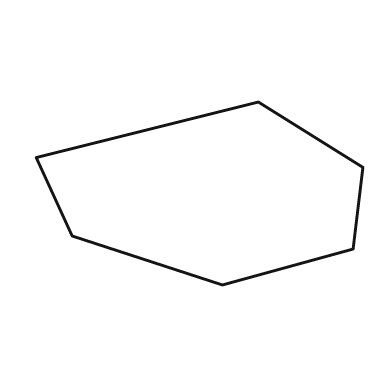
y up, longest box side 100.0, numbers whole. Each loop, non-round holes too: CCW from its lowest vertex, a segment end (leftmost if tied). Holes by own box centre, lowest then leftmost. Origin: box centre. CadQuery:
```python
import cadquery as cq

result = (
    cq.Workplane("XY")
    .moveTo(7.0, -28.0)
    .lineTo(47.0, -17.0)
    .lineTo(50.0, 8.0)
    .lineTo(18.0, 28.0)
    .lineTo(-50.0, 11.0)
    .lineTo(-39.0, -13.0)
    .close()
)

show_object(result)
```